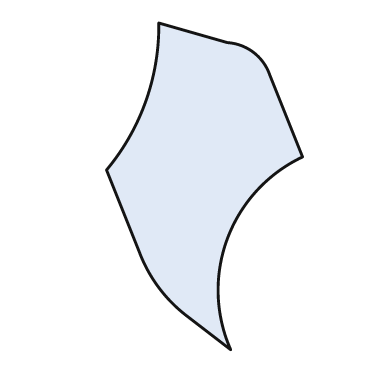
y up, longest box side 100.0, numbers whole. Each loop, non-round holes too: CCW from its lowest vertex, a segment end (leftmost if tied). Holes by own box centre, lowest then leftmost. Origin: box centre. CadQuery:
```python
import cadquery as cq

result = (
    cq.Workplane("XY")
    .moveTo(8.0, -50.0)
    .threePointArc((7.0, -16.0), (30.0, 9.0))
    .lineTo(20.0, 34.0)
    .threePointArc((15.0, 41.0), (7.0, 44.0))
    .lineTo(-14.0, 50.0)
    .threePointArc((-18.0, 26.0), (-30.0, 5.0))
    .lineTo(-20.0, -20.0)
    .threePointArc((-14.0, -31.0), (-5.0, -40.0))
    .close()
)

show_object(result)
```